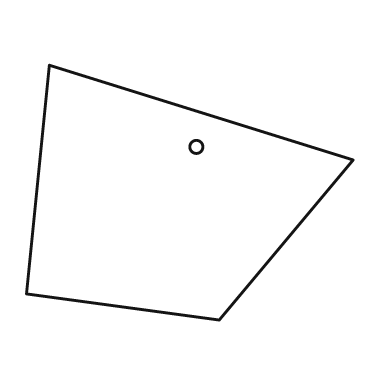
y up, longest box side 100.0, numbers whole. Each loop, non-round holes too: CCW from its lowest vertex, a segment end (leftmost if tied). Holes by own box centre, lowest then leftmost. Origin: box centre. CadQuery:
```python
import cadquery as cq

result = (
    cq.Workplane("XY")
    .moveTo(9.0, -39.0)
    .lineTo(50.0, 10.0)
    .lineTo(-43.0, 39.0)
    .lineTo(-50.0, -31.0)
    .close()
    .moveTo(2.0, 14.0)
    .circle(2.0)
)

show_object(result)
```